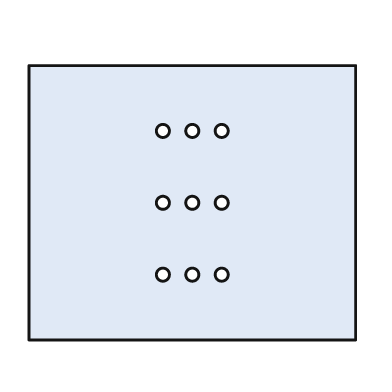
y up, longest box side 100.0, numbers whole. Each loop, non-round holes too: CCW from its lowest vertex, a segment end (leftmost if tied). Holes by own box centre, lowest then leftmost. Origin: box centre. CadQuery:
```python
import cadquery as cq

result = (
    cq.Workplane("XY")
    .moveTo(-50.0, -42.0)
    .lineTo(50.0, -42.0)
    .lineTo(50.0, 42.0)
    .lineTo(-50.0, 42.0)
    .close()
    .moveTo(-9.0, -22.0)
    .circle(2.0)
    .moveTo(0.0, -22.0)
    .circle(2.0)
    .moveTo(9.0, -22.0)
    .circle(2.0)
    .moveTo(-9.0, 0.0)
    .circle(2.0)
    .moveTo(0.0, 0.0)
    .circle(2.0)
    .moveTo(9.0, 0.0)
    .circle(2.0)
    .moveTo(-9.0, 22.0)
    .circle(2.0)
    .moveTo(0.0, 22.0)
    .circle(2.0)
    .moveTo(9.0, 22.0)
    .circle(2.0)
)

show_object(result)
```